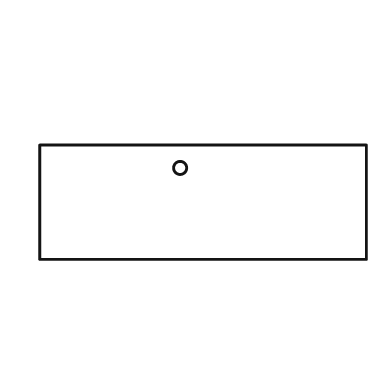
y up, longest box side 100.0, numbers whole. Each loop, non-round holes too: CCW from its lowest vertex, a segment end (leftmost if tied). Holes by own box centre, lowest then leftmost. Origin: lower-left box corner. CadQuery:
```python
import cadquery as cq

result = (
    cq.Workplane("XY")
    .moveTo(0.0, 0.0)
    .lineTo(100.0, 0.0)
    .lineTo(100.0, 35.0)
    .lineTo(0.0, 35.0)
    .close()
    .moveTo(43.0, 28.0)
    .circle(2.0)
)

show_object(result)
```